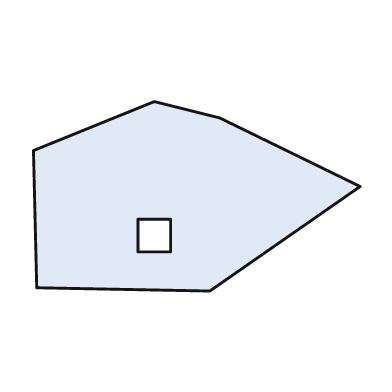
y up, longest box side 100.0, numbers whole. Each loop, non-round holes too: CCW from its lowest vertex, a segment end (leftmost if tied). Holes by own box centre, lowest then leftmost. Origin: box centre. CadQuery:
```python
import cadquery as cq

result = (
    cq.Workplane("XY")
    .moveTo(4.0, -29.0)
    .lineTo(50.0, 3.0)
    .lineTo(7.0, 24.0)
    .lineTo(-13.0, 29.0)
    .lineTo(-50.0, 14.0)
    .lineTo(-49.0, -28.0)
    .close()
    .moveTo(-18.0, -17.0)
    .lineTo(-8.0, -17.0)
    .lineTo(-8.0, -7.0)
    .lineTo(-18.0, -7.0)
    .close()
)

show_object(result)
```